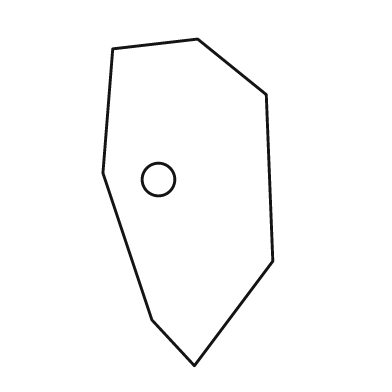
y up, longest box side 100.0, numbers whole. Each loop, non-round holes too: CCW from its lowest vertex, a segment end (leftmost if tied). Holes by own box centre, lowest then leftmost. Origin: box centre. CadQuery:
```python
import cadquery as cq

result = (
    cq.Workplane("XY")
    .moveTo(2.0, -50.0)
    .lineTo(26.0, -18.0)
    .lineTo(24.0, 33.0)
    .lineTo(3.0, 50.0)
    .lineTo(-23.0, 47.0)
    .lineTo(-26.0, 9.0)
    .lineTo(-11.0, -36.0)
    .close()
    .moveTo(-9.0, 7.0)
    .circle(5.0)
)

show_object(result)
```